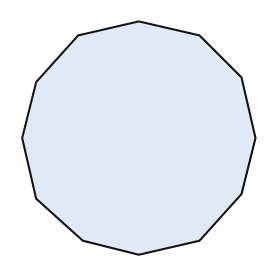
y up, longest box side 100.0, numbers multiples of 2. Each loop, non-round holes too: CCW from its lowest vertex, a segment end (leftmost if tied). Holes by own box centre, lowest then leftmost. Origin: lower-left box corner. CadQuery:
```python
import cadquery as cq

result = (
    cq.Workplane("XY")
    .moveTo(50.0, 0.0)
    .lineTo(76.0, 6.0)
    .lineTo(94.0, 26.0)
    .lineTo(100.0, 50.0)
    .lineTo(94.0, 76.0)
    .lineTo(76.0, 94.0)
    .lineTo(50.0, 100.0)
    .lineTo(24.0, 94.0)
    .lineTo(6.0, 74.0)
    .lineTo(0.0, 50.0)
    .lineTo(6.0, 24.0)
    .lineTo(26.0, 6.0)
    .close()
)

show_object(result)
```